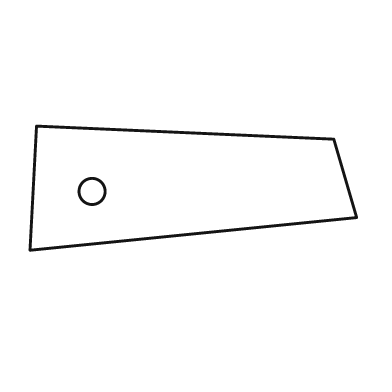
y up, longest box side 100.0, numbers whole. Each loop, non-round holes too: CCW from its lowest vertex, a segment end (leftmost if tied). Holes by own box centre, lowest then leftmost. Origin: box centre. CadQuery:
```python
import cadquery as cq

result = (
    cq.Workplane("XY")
    .moveTo(-50.0, -19.0)
    .lineTo(50.0, -9.0)
    .lineTo(43.0, 15.0)
    .lineTo(-48.0, 19.0)
    .close()
    .moveTo(-31.0, -1.0)
    .circle(4.0)
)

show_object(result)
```